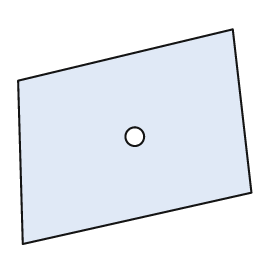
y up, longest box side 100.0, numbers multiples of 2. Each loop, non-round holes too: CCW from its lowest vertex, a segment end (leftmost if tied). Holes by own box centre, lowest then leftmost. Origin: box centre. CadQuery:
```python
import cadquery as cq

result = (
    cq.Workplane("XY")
    .moveTo(-48.0, -46.0)
    .lineTo(50.0, -24.0)
    .lineTo(42.0, 46.0)
    .lineTo(-50.0, 24.0)
    .close()
    .moveTo(0.0, 0.0)
    .circle(4.0)
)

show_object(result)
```